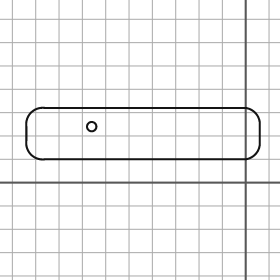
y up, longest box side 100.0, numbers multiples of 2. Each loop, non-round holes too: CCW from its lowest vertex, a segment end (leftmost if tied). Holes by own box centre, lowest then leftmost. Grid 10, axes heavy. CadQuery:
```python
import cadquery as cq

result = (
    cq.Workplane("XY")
    .moveTo(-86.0, 10.0)
    .lineTo(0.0, 10.0)
    .threePointArc((4.0, 12.0), (6.0, 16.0))
    .lineTo(6.0, 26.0)
    .threePointArc((4.0, 30.0), (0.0, 32.0))
    .lineTo(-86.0, 32.0)
    .threePointArc((-92.0, 30.0), (-94.0, 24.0))
    .lineTo(-94.0, 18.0)
    .threePointArc((-92.0, 12.0), (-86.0, 10.0))
    .close()
    .moveTo(-66.0, 24.0)
    .circle(2.0)
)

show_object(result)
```